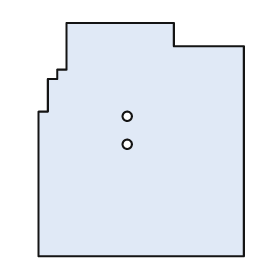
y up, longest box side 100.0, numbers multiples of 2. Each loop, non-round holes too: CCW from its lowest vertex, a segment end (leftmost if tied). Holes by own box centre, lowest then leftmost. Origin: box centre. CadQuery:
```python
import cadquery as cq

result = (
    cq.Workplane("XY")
    .moveTo(-44.0, -50.0)
    .lineTo(44.0, -50.0)
    .lineTo(44.0, 40.0)
    .lineTo(14.0, 40.0)
    .lineTo(14.0, 50.0)
    .lineTo(-32.0, 50.0)
    .lineTo(-32.0, 30.0)
    .lineTo(-36.0, 30.0)
    .lineTo(-36.0, 26.0)
    .lineTo(-40.0, 26.0)
    .lineTo(-40.0, 12.0)
    .lineTo(-44.0, 12.0)
    .close()
    .moveTo(-6.0, -2.0)
    .circle(2.0)
    .moveTo(-6.0, 10.0)
    .circle(2.0)
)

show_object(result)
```